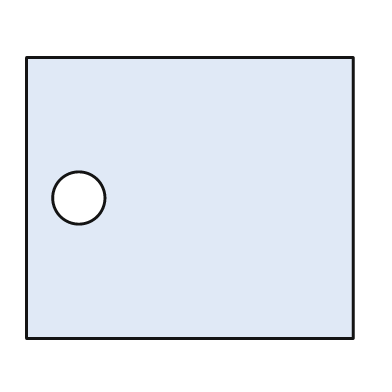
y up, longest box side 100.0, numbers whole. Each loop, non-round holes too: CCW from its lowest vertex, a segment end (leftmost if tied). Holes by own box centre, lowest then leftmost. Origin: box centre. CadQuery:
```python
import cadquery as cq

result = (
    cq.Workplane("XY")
    .moveTo(-50.0, -43.0)
    .lineTo(50.0, -43.0)
    .lineTo(50.0, 43.0)
    .lineTo(-50.0, 43.0)
    .close()
    .moveTo(-34.0, 0.0)
    .circle(8.0)
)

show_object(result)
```